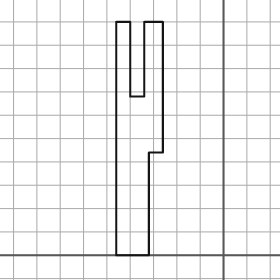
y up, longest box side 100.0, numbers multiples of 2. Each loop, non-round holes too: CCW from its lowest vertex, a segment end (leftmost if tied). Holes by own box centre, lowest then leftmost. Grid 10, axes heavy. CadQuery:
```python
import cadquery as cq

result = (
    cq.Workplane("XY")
    .moveTo(-46.0, 0.0)
    .lineTo(-32.0, 0.0)
    .lineTo(-32.0, 44.0)
    .lineTo(-26.0, 44.0)
    .lineTo(-26.0, 100.0)
    .lineTo(-34.0, 100.0)
    .lineTo(-34.0, 68.0)
    .lineTo(-40.0, 68.0)
    .lineTo(-40.0, 100.0)
    .lineTo(-46.0, 100.0)
    .close()
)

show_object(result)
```